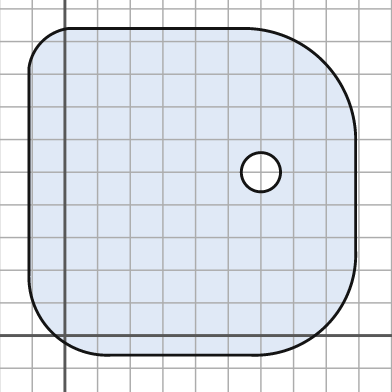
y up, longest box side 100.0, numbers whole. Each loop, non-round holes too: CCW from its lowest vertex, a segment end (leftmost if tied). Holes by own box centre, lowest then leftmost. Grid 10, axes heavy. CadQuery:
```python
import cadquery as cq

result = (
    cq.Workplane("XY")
    .moveTo(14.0, -6.0)
    .lineTo(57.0, -6.0)
    .threePointArc((80.0, 3.0), (89.0, 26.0))
    .lineTo(89.0, 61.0)
    .threePointArc((79.0, 84.0), (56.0, 94.0))
    .lineTo(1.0, 94.0)
    .threePointArc((-7.0, 90.0), (-11.0, 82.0))
    .lineTo(-11.0, 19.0)
    .threePointArc((-4.0, 1.0), (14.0, -6.0))
    .close()
    .moveTo(60.0, 50.0)
    .circle(6.0)
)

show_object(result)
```